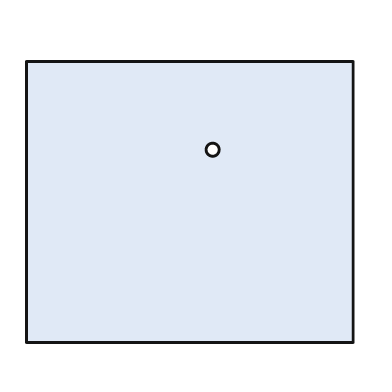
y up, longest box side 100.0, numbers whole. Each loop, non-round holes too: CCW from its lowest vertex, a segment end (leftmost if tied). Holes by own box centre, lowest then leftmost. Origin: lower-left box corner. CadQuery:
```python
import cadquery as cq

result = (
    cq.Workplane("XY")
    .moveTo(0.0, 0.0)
    .lineTo(100.0, 0.0)
    .lineTo(100.0, 86.0)
    .lineTo(0.0, 86.0)
    .close()
    .moveTo(57.0, 59.0)
    .circle(2.0)
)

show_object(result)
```